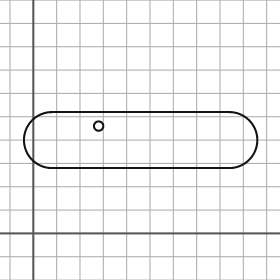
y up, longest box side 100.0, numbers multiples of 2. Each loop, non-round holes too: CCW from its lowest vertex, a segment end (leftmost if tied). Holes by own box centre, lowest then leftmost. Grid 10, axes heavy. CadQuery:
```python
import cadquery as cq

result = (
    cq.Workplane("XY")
    .moveTo(8.0, 28.0)
    .lineTo(84.0, 28.0)
    .threePointArc((96.0, 40.0), (84.0, 52.0))
    .lineTo(8.0, 52.0)
    .threePointArc((-4.0, 40.0), (8.0, 28.0))
    .close()
    .moveTo(28.0, 46.0)
    .circle(2.0)
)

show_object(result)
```